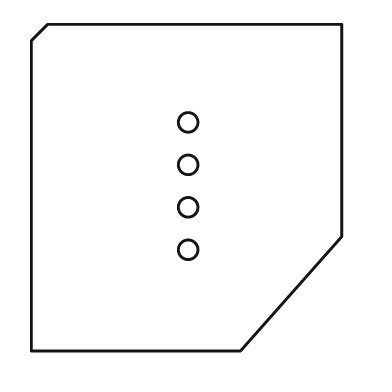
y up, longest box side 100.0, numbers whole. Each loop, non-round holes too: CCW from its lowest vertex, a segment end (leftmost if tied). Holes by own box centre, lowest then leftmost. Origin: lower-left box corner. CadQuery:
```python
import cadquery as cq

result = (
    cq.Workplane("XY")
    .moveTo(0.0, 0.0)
    .lineTo(64.0, 0.0)
    .lineTo(95.0, 35.0)
    .lineTo(95.0, 100.0)
    .lineTo(5.0, 100.0)
    .lineTo(0.0, 95.0)
    .close()
    .moveTo(48.0, 31.0)
    .circle(3.0)
    .moveTo(48.0, 44.0)
    .circle(3.0)
    .moveTo(48.0, 57.0)
    .circle(3.0)
    .moveTo(48.0, 70.0)
    .circle(3.0)
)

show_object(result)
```